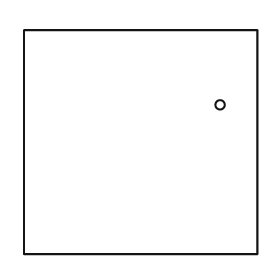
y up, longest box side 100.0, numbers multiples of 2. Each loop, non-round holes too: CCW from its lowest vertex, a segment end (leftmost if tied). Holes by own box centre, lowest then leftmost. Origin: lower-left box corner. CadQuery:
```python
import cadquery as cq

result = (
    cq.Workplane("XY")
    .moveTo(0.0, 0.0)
    .lineTo(100.0, 0.0)
    .lineTo(100.0, 96.0)
    .lineTo(0.0, 96.0)
    .close()
    .moveTo(84.0, 64.0)
    .circle(2.0)
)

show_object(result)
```